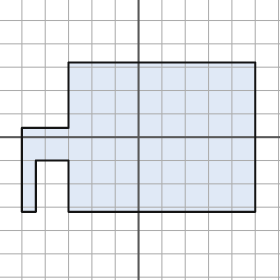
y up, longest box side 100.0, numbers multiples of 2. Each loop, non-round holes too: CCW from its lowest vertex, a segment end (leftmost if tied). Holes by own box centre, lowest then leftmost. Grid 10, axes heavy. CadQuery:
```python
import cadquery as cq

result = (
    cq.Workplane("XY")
    .moveTo(-50.0, -32.0)
    .lineTo(-44.0, -32.0)
    .lineTo(-44.0, -10.0)
    .lineTo(-30.0, -10.0)
    .lineTo(-30.0, -32.0)
    .lineTo(50.0, -32.0)
    .lineTo(50.0, 32.0)
    .lineTo(-30.0, 32.0)
    .lineTo(-30.0, 4.0)
    .lineTo(-50.0, 4.0)
    .close()
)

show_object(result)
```